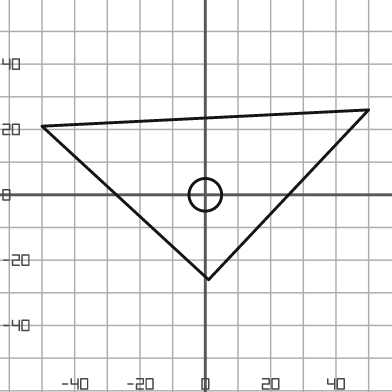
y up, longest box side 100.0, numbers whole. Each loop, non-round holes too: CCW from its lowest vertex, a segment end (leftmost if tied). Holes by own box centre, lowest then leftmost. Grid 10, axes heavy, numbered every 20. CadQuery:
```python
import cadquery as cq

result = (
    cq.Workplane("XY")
    .moveTo(1.0, -26.0)
    .lineTo(50.0, 26.0)
    .lineTo(-50.0, 21.0)
    .close()
    .moveTo(0.0, 0.0)
    .circle(5.0)
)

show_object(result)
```